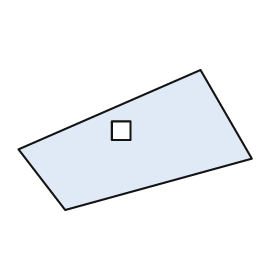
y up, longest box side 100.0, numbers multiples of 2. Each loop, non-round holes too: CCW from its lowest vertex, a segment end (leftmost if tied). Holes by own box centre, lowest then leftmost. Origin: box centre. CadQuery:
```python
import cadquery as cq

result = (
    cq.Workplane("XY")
    .moveTo(-30.0, -30.0)
    .lineTo(50.0, -8.0)
    .lineTo(28.0, 30.0)
    .lineTo(-50.0, -4.0)
    .close()
    .moveTo(-10.0, 0.0)
    .lineTo(-2.0, 0.0)
    .lineTo(-2.0, 8.0)
    .lineTo(-10.0, 8.0)
    .close()
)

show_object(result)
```